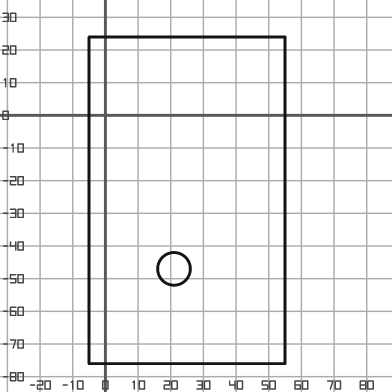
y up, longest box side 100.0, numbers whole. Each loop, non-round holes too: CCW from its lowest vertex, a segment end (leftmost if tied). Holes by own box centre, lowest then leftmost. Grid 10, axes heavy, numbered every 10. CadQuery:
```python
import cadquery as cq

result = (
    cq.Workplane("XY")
    .moveTo(-5.0, -76.0)
    .lineTo(55.0, -76.0)
    .lineTo(55.0, 24.0)
    .lineTo(-5.0, 24.0)
    .close()
    .moveTo(21.0, -47.0)
    .circle(5.0)
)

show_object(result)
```